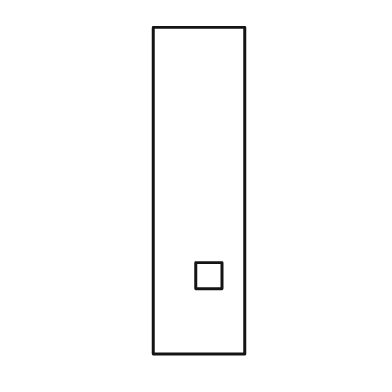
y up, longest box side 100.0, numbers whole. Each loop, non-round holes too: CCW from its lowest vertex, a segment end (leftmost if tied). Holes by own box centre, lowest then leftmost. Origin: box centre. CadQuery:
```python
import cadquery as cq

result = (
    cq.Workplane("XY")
    .moveTo(-14.0, -50.0)
    .lineTo(14.0, -50.0)
    .lineTo(14.0, 50.0)
    .lineTo(-14.0, 50.0)
    .close()
    .moveTo(-1.0, -30.0)
    .lineTo(7.0, -30.0)
    .lineTo(7.0, -22.0)
    .lineTo(-1.0, -22.0)
    .close()
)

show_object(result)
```